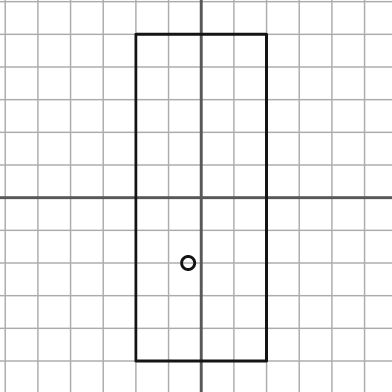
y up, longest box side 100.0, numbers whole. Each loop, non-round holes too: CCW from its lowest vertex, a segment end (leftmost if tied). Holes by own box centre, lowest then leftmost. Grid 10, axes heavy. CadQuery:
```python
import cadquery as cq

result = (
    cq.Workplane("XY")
    .moveTo(-20.0, -50.0)
    .lineTo(20.0, -50.0)
    .lineTo(20.0, 50.0)
    .lineTo(-20.0, 50.0)
    .close()
    .moveTo(-4.0, -20.0)
    .circle(2.0)
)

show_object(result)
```